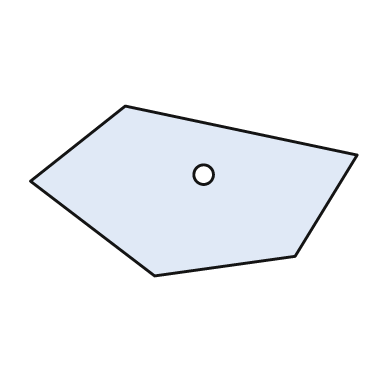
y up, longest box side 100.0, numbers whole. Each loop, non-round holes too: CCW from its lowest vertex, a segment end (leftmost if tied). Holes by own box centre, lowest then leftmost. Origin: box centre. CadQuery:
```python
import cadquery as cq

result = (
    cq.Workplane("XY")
    .moveTo(-12.0, -26.0)
    .lineTo(31.0, -20.0)
    .lineTo(50.0, 11.0)
    .lineTo(-21.0, 26.0)
    .lineTo(-50.0, 3.0)
    .close()
    .moveTo(3.0, 5.0)
    .circle(3.0)
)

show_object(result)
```